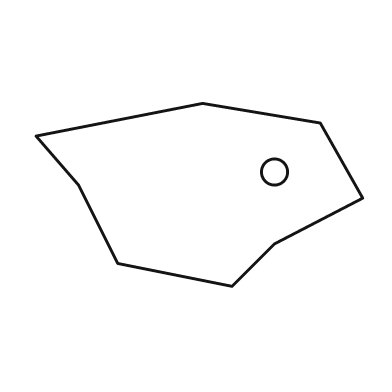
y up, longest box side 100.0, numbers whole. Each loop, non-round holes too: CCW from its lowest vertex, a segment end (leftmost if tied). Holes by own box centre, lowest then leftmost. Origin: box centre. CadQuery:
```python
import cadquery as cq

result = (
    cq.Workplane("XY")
    .moveTo(10.0, -28.0)
    .lineTo(23.0, -15.0)
    .lineTo(50.0, -1.0)
    .lineTo(37.0, 22.0)
    .lineTo(1.0, 28.0)
    .lineTo(-50.0, 18.0)
    .lineTo(-37.0, 3.0)
    .lineTo(-25.0, -21.0)
    .close()
    .moveTo(23.0, 7.0)
    .circle(4.0)
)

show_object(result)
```